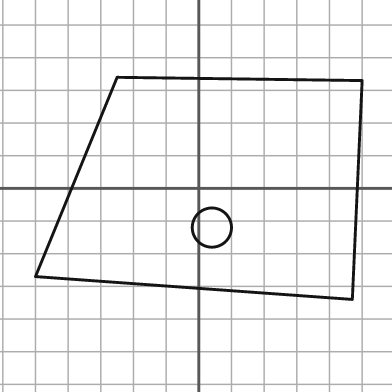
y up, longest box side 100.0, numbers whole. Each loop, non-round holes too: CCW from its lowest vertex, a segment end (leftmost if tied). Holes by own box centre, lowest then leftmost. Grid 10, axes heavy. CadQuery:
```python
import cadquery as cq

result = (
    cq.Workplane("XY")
    .moveTo(47.0, -34.0)
    .lineTo(50.0, 33.0)
    .lineTo(-25.0, 34.0)
    .lineTo(-50.0, -27.0)
    .close()
    .moveTo(4.0, -12.0)
    .circle(6.0)
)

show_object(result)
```